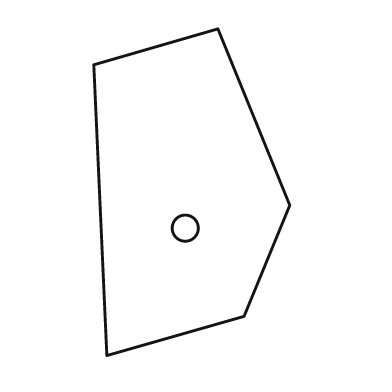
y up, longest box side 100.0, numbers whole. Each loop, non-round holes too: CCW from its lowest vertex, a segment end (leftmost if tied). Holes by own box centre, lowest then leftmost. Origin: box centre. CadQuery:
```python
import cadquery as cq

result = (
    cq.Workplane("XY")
    .moveTo(-26.0, -50.0)
    .lineTo(16.0, -38.0)
    .lineTo(30.0, -4.0)
    .lineTo(8.0, 50.0)
    .lineTo(-30.0, 39.0)
    .close()
    .moveTo(-2.0, -11.0)
    .circle(4.0)
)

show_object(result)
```